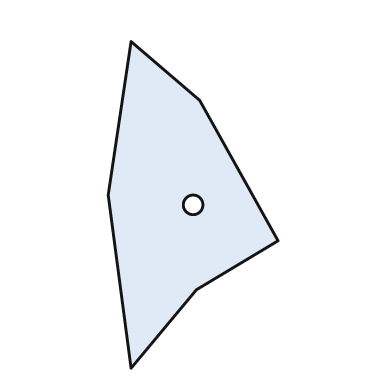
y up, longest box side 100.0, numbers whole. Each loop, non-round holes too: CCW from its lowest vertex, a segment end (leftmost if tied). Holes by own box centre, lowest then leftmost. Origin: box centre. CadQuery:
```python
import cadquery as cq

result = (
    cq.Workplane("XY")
    .moveTo(-19.0, -50.0)
    .lineTo(1.0, -26.0)
    .lineTo(26.0, -11.0)
    .lineTo(2.0, 32.0)
    .lineTo(-19.0, 50.0)
    .lineTo(-26.0, 3.0)
    .close()
    .moveTo(0.0, 0.0)
    .circle(3.0)
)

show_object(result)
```